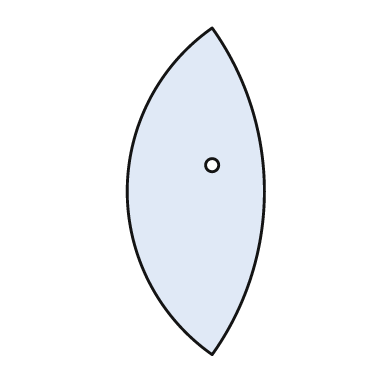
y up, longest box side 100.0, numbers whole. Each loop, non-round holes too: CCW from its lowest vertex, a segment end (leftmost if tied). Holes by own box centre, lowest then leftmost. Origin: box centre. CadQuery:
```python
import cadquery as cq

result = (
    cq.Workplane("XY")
    .moveTo(5.0, -50.0)
    .threePointArc((21.0, 0.0), (5.0, 50.0))
    .threePointArc((-21.0, 0.0), (5.0, -50.0))
    .close()
    .moveTo(5.0, 8.0)
    .circle(2.0)
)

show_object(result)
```